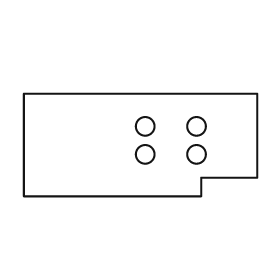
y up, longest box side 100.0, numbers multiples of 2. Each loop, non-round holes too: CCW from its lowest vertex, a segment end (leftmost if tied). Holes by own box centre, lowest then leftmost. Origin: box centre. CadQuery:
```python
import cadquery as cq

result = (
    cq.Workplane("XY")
    .moveTo(-50.0, -22.0)
    .lineTo(26.0, -22.0)
    .lineTo(26.0, -14.0)
    .lineTo(50.0, -14.0)
    .lineTo(50.0, 22.0)
    .lineTo(-50.0, 22.0)
    .close()
    .moveTo(2.0, -4.0)
    .circle(4.0)
    .moveTo(24.0, -4.0)
    .circle(4.0)
    .moveTo(2.0, 8.0)
    .circle(4.0)
    .moveTo(24.0, 8.0)
    .circle(4.0)
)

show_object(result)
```